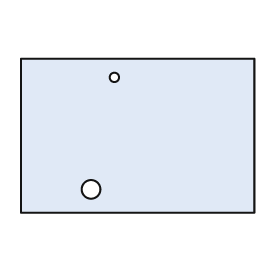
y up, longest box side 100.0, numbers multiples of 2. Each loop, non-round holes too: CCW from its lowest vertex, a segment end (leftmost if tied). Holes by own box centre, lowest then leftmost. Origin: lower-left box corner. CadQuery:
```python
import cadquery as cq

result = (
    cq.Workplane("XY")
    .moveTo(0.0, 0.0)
    .lineTo(100.0, 0.0)
    .lineTo(100.0, 66.0)
    .lineTo(0.0, 66.0)
    .close()
    .moveTo(30.0, 10.0)
    .circle(4.0)
    .moveTo(40.0, 58.0)
    .circle(2.0)
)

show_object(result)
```